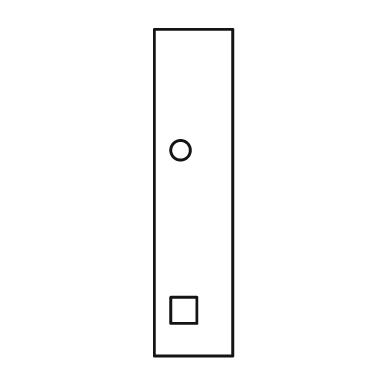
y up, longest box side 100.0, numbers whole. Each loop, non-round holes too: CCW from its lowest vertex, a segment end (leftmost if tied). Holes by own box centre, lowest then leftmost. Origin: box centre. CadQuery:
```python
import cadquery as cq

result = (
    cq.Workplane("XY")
    .moveTo(-12.0, -50.0)
    .lineTo(12.0, -50.0)
    .lineTo(12.0, 50.0)
    .lineTo(-12.0, 50.0)
    .close()
    .moveTo(-7.0, -40.0)
    .lineTo(1.0, -40.0)
    .lineTo(1.0, -32.0)
    .lineTo(-7.0, -32.0)
    .close()
    .moveTo(-4.0, 13.0)
    .circle(3.0)
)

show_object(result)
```